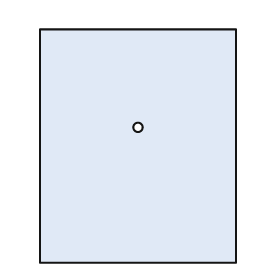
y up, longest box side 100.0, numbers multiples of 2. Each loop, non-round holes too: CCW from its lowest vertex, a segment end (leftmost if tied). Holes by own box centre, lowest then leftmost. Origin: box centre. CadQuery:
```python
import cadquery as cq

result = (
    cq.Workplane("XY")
    .moveTo(-42.0, -50.0)
    .lineTo(42.0, -50.0)
    .lineTo(42.0, 50.0)
    .lineTo(-42.0, 50.0)
    .close()
    .moveTo(0.0, 8.0)
    .circle(2.0)
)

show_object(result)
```